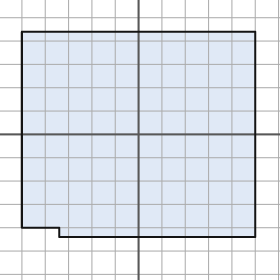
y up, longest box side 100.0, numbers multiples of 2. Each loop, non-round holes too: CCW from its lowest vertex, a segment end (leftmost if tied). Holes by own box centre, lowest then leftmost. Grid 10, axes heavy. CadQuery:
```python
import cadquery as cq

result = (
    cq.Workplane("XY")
    .moveTo(-34.0, -44.0)
    .lineTo(50.0, -44.0)
    .lineTo(50.0, 44.0)
    .lineTo(-50.0, 44.0)
    .lineTo(-50.0, -40.0)
    .lineTo(-34.0, -40.0)
    .close()
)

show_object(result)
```